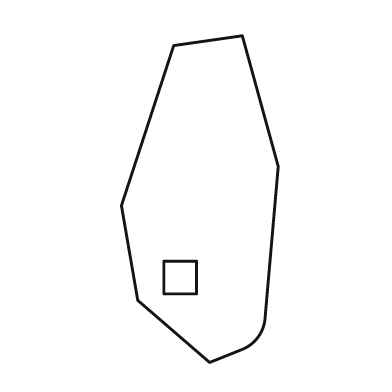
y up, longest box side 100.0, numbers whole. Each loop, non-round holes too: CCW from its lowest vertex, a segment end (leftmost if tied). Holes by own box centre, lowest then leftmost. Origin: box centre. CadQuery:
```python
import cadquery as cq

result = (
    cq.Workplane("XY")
    .moveTo(3.0, -50.0)
    .lineTo(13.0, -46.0)
    .threePointArc((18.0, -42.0), (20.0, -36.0))
    .lineTo(24.0, 10.0)
    .lineTo(13.0, 50.0)
    .lineTo(-8.0, 47.0)
    .lineTo(-24.0, -2.0)
    .lineTo(-19.0, -31.0)
    .close()
    .moveTo(-11.0, -29.0)
    .lineTo(-1.0, -29.0)
    .lineTo(-1.0, -19.0)
    .lineTo(-11.0, -19.0)
    .close()
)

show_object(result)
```